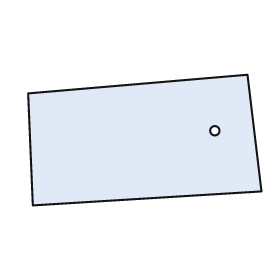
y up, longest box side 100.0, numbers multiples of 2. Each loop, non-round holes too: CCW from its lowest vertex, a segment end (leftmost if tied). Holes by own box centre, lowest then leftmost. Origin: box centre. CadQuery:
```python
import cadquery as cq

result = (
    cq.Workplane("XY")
    .moveTo(-48.0, -28.0)
    .lineTo(50.0, -22.0)
    .lineTo(44.0, 28.0)
    .lineTo(-50.0, 20.0)
    .close()
    .moveTo(30.0, 4.0)
    .circle(2.0)
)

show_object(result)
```